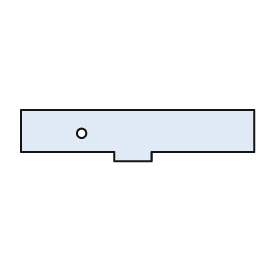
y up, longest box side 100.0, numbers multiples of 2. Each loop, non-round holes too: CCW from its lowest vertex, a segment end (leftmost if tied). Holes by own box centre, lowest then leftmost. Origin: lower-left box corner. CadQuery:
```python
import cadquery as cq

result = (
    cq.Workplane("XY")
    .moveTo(40.0, 0.0)
    .lineTo(56.0, 0.0)
    .lineTo(56.0, 4.0)
    .lineTo(100.0, 4.0)
    .lineTo(100.0, 22.0)
    .lineTo(0.0, 22.0)
    .lineTo(0.0, 4.0)
    .lineTo(40.0, 4.0)
    .close()
    .moveTo(26.0, 12.0)
    .circle(2.0)
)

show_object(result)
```